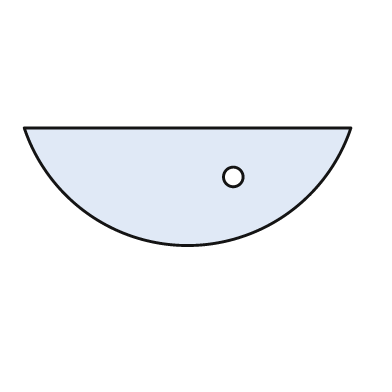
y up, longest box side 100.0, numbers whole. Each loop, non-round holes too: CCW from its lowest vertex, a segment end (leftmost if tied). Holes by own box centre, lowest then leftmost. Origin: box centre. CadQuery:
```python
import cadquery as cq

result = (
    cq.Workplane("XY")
    .moveTo(-50.0, 18.0)
    .threePointArc((0.0, -18.0), (50.0, 18.0))
    .close()
    .moveTo(14.0, 3.0)
    .circle(3.0)
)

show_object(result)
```